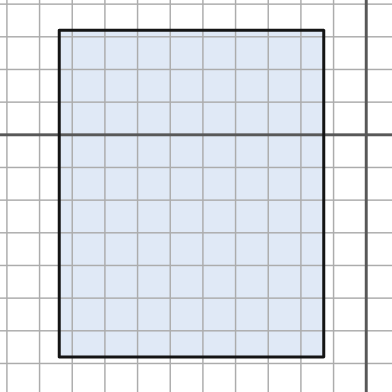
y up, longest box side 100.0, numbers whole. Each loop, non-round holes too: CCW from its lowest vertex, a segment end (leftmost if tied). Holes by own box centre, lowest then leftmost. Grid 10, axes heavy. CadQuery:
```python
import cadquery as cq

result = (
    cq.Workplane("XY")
    .moveTo(-94.0, -68.0)
    .lineTo(-13.0, -68.0)
    .lineTo(-13.0, 32.0)
    .lineTo(-94.0, 32.0)
    .close()
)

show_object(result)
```